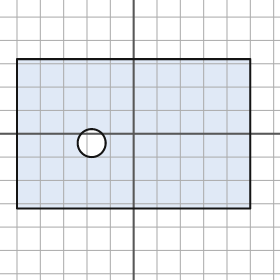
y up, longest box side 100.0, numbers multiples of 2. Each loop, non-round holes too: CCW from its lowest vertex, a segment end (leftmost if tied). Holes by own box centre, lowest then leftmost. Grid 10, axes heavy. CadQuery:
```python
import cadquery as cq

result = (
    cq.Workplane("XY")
    .moveTo(-50.0, -32.0)
    .lineTo(50.0, -32.0)
    .lineTo(50.0, 32.0)
    .lineTo(-50.0, 32.0)
    .close()
    .moveTo(-18.0, -4.0)
    .circle(6.0)
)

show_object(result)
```